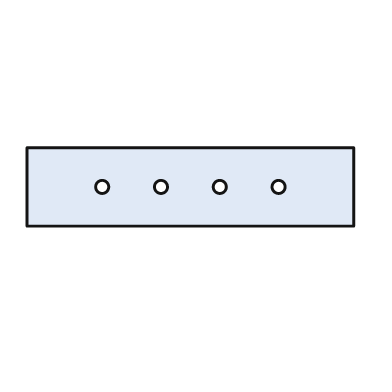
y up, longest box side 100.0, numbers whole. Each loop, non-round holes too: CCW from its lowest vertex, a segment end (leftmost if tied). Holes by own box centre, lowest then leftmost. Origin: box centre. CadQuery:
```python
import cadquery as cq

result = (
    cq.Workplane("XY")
    .moveTo(-50.0, -12.0)
    .lineTo(50.0, -12.0)
    .lineTo(50.0, 12.0)
    .lineTo(-50.0, 12.0)
    .close()
    .moveTo(-27.0, 0.0)
    .circle(2.0)
    .moveTo(-9.0, 0.0)
    .circle(2.0)
    .moveTo(9.0, 0.0)
    .circle(2.0)
    .moveTo(27.0, 0.0)
    .circle(2.0)
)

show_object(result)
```